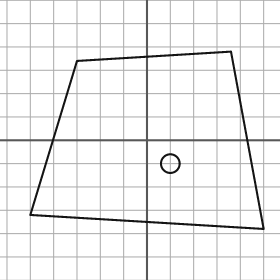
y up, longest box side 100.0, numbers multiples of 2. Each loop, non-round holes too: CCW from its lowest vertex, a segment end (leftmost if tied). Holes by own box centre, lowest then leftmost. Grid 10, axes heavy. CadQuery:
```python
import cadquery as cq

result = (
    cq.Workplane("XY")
    .moveTo(50.0, -38.0)
    .lineTo(36.0, 38.0)
    .lineTo(-30.0, 34.0)
    .lineTo(-50.0, -32.0)
    .close()
    .moveTo(10.0, -10.0)
    .circle(4.0)
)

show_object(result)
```